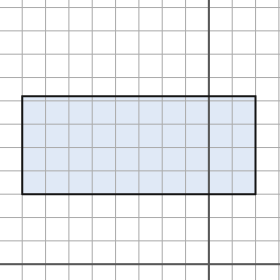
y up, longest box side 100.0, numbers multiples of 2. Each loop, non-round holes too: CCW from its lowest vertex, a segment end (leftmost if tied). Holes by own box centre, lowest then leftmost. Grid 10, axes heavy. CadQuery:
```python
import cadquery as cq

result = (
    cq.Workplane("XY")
    .moveTo(-80.0, 30.0)
    .lineTo(20.0, 30.0)
    .lineTo(20.0, 72.0)
    .lineTo(-80.0, 72.0)
    .close()
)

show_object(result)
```